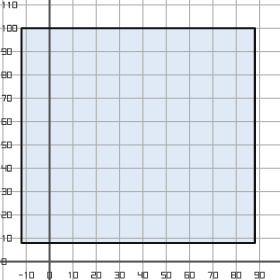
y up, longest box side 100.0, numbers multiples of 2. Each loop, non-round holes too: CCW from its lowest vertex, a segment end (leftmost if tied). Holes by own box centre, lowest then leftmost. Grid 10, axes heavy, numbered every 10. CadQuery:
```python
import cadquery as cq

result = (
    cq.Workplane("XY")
    .moveTo(-12.0, 8.0)
    .lineTo(88.0, 8.0)
    .lineTo(88.0, 100.0)
    .lineTo(-12.0, 100.0)
    .close()
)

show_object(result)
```